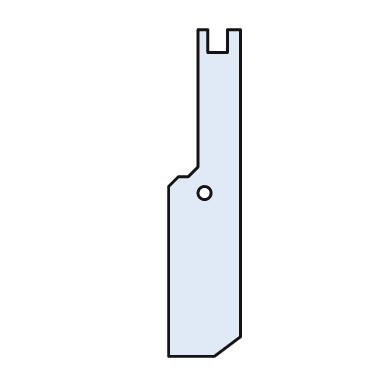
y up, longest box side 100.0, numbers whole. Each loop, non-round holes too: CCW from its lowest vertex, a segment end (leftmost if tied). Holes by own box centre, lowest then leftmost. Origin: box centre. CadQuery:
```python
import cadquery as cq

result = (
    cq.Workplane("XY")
    .moveTo(-11.0, -50.0)
    .lineTo(3.0, -50.0)
    .lineTo(11.0, -44.0)
    .lineTo(11.0, 50.0)
    .lineTo(7.0, 50.0)
    .lineTo(7.0, 43.0)
    .lineTo(1.0, 43.0)
    .lineTo(1.0, 50.0)
    .lineTo(-2.0, 50.0)
    .lineTo(-2.0, 8.0)
    .lineTo(-5.0, 5.0)
    .lineTo(-8.0, 5.0)
    .lineTo(-11.0, 2.0)
    .close()
    .moveTo(0.0, 0.0)
    .circle(2.0)
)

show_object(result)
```